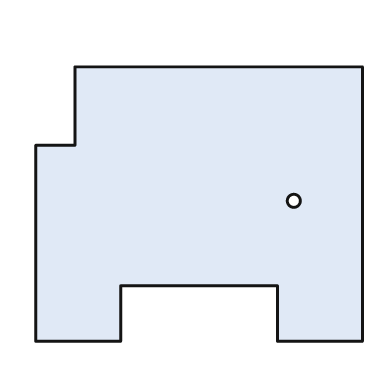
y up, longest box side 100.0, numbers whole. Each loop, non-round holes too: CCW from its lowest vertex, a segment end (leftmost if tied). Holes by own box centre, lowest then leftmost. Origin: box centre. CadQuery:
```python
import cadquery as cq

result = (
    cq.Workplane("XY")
    .moveTo(-50.0, -42.0)
    .lineTo(-24.0, -42.0)
    .lineTo(-24.0, -25.0)
    .lineTo(24.0, -25.0)
    .lineTo(24.0, -42.0)
    .lineTo(50.0, -42.0)
    .lineTo(50.0, 42.0)
    .lineTo(-38.0, 42.0)
    .lineTo(-38.0, 18.0)
    .lineTo(-50.0, 18.0)
    .close()
    .moveTo(29.0, 1.0)
    .circle(2.0)
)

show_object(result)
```